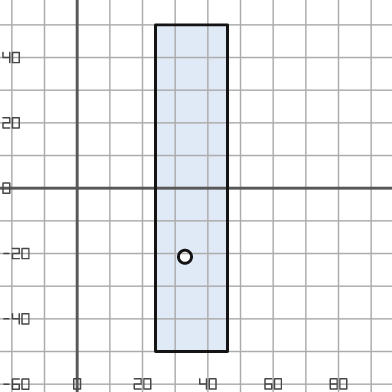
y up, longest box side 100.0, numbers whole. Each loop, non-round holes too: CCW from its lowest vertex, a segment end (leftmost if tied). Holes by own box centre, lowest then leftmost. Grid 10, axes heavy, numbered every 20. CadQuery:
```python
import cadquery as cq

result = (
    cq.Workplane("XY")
    .moveTo(24.0, -50.0)
    .lineTo(46.0, -50.0)
    .lineTo(46.0, 50.0)
    .lineTo(24.0, 50.0)
    .close()
    .moveTo(33.0, -21.0)
    .circle(2.0)
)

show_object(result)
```